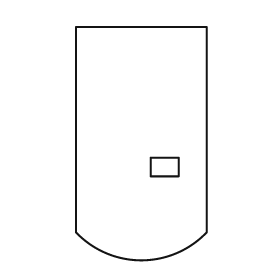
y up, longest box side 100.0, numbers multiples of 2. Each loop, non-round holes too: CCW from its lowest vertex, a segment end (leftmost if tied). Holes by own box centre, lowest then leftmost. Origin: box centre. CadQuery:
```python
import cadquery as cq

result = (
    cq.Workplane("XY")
    .moveTo(-28.0, -38.0)
    .threePointArc((0.0, -50.0), (28.0, -38.0))
    .lineTo(28.0, 50.0)
    .lineTo(-28.0, 50.0)
    .close()
    .moveTo(4.0, -14.0)
    .lineTo(16.0, -14.0)
    .lineTo(16.0, -6.0)
    .lineTo(4.0, -6.0)
    .close()
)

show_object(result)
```